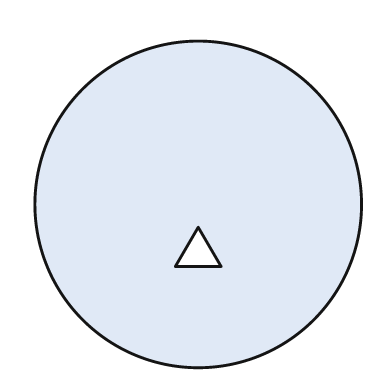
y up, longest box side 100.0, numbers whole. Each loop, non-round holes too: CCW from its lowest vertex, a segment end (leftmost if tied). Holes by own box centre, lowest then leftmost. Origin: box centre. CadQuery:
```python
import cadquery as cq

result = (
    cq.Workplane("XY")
    .moveTo(0.0, 0.0)
    .circle(50.0)
    .moveTo(-7.0, -19.0)
    .lineTo(7.0, -19.0)
    .lineTo(0.0, -7.0)
    .close()
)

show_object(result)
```